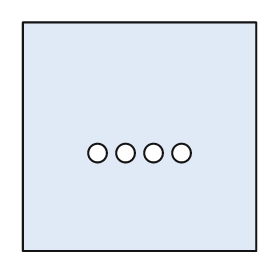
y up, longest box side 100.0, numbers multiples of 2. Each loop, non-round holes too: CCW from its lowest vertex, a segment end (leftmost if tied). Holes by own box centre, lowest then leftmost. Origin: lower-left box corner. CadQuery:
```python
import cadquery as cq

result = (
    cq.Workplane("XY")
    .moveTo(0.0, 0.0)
    .lineTo(100.0, 0.0)
    .lineTo(100.0, 98.0)
    .lineTo(0.0, 98.0)
    .close()
    .moveTo(32.0, 42.0)
    .circle(4.0)
    .moveTo(44.0, 42.0)
    .circle(4.0)
    .moveTo(56.0, 42.0)
    .circle(4.0)
    .moveTo(68.0, 42.0)
    .circle(4.0)
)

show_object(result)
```